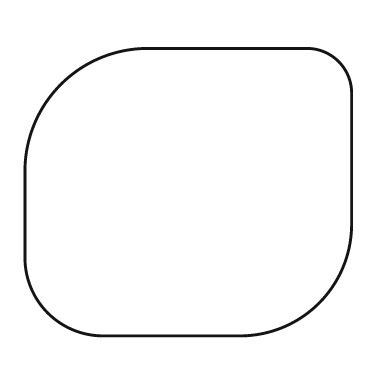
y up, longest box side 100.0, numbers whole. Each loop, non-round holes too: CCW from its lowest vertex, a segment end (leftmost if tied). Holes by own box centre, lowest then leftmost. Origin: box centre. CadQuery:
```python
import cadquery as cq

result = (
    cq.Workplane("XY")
    .moveTo(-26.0, -44.0)
    .lineTo(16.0, -44.0)
    .threePointArc((40.0, -34.0), (50.0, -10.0))
    .lineTo(50.0, 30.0)
    .threePointArc((46.0, 40.0), (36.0, 44.0))
    .lineTo(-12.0, 44.0)
    .threePointArc((-39.0, 33.0), (-50.0, 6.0))
    .lineTo(-50.0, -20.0)
    .threePointArc((-43.0, -37.0), (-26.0, -44.0))
    .close()
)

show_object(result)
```